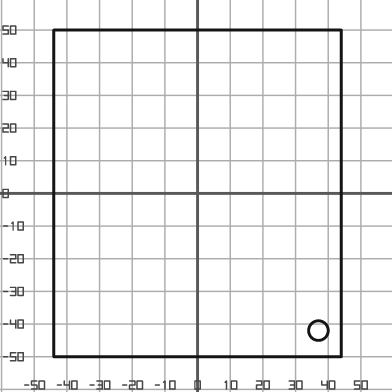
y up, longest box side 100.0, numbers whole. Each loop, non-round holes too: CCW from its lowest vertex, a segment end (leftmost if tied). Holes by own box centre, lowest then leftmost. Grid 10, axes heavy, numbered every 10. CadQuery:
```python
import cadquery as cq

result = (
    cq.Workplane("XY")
    .moveTo(-44.0, -50.0)
    .lineTo(44.0, -50.0)
    .lineTo(44.0, 50.0)
    .lineTo(-44.0, 50.0)
    .close()
    .moveTo(37.0, -42.0)
    .circle(3.0)
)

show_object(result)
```